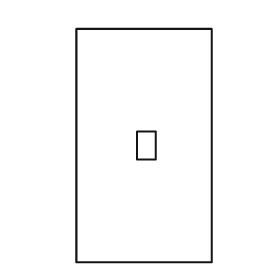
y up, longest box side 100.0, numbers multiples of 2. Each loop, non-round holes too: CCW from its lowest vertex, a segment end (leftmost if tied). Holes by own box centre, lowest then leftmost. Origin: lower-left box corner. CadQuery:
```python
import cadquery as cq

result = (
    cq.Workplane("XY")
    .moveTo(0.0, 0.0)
    .lineTo(58.0, 0.0)
    .lineTo(58.0, 100.0)
    .lineTo(0.0, 100.0)
    .close()
    .moveTo(26.0, 44.0)
    .lineTo(34.0, 44.0)
    .lineTo(34.0, 56.0)
    .lineTo(26.0, 56.0)
    .close()
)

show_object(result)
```